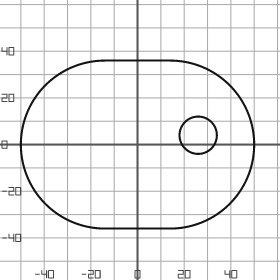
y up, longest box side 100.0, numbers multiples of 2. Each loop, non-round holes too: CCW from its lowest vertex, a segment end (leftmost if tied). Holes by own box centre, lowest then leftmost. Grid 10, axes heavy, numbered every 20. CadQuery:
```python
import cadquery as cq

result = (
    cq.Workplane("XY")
    .moveTo(-14.0, -36.0)
    .lineTo(14.0, -36.0)
    .threePointArc((50.0, 0.0), (14.0, 36.0))
    .lineTo(-14.0, 36.0)
    .threePointArc((-50.0, 0.0), (-14.0, -36.0))
    .close()
    .moveTo(26.0, 4.0)
    .circle(8.0)
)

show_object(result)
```